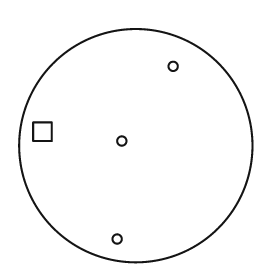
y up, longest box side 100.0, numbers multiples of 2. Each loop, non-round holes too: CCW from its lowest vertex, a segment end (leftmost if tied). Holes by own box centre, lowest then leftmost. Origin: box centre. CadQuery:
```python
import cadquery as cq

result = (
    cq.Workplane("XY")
    .moveTo(0.0, 0.0)
    .circle(50.0)
    .moveTo(-8.0, -40.0)
    .circle(2.0)
    .moveTo(-6.0, 2.0)
    .circle(2.0)
    .moveTo(-44.0, 2.0)
    .lineTo(-36.0, 2.0)
    .lineTo(-36.0, 10.0)
    .lineTo(-44.0, 10.0)
    .close()
    .moveTo(16.0, 34.0)
    .circle(2.0)
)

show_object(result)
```